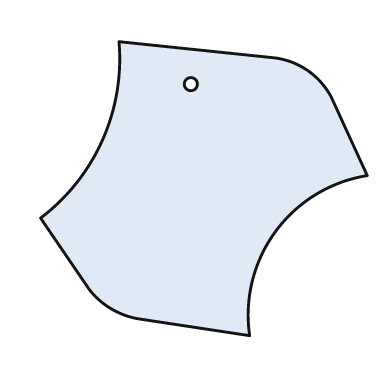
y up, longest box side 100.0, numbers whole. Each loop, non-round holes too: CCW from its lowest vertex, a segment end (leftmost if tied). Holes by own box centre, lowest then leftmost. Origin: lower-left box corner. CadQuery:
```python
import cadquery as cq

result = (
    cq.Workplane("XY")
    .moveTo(64.0, 0.0)
    .threePointArc((72.0, 32.0), (100.0, 49.0))
    .lineTo(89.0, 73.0)
    .threePointArc((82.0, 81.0), (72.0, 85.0))
    .lineTo(24.0, 90.0)
    .threePointArc((19.0, 60.0), (0.0, 36.0))
    .lineTo(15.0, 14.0)
    .threePointArc((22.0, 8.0), (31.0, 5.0))
    .close()
    .moveTo(46.0, 77.0)
    .circle(2.0)
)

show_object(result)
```